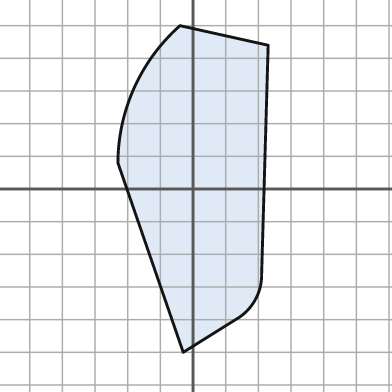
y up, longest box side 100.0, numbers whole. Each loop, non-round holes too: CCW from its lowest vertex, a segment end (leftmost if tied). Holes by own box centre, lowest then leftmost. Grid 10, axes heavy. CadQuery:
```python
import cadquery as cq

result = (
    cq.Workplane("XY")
    .moveTo(-3.0, -50.0)
    .lineTo(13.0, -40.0)
    .threePointArc((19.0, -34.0), (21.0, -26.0))
    .lineTo(23.0, 44.0)
    .lineTo(-4.0, 50.0)
    .threePointArc((-18.0, 31.0), (-23.0, 8.0))
    .close()
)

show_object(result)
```